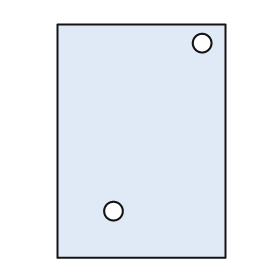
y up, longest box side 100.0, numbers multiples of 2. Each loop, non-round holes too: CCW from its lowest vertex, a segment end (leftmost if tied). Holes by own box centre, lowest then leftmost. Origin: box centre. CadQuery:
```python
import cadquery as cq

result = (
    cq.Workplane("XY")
    .moveTo(-36.0, -50.0)
    .lineTo(36.0, -50.0)
    .lineTo(36.0, 50.0)
    .lineTo(-36.0, 50.0)
    .close()
    .moveTo(-12.0, -30.0)
    .circle(4.0)
    .moveTo(26.0, 42.0)
    .circle(4.0)
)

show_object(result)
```